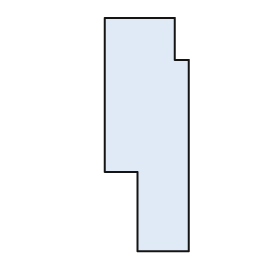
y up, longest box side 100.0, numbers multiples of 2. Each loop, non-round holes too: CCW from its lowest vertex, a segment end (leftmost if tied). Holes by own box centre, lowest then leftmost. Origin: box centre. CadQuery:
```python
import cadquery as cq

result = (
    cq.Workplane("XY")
    .moveTo(-4.0, -50.0)
    .lineTo(18.0, -50.0)
    .lineTo(18.0, 32.0)
    .lineTo(12.0, 32.0)
    .lineTo(12.0, 50.0)
    .lineTo(-18.0, 50.0)
    .lineTo(-18.0, -16.0)
    .lineTo(-4.0, -16.0)
    .close()
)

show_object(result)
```